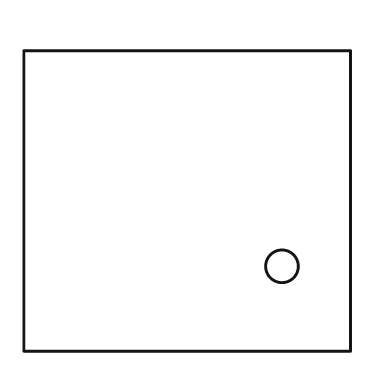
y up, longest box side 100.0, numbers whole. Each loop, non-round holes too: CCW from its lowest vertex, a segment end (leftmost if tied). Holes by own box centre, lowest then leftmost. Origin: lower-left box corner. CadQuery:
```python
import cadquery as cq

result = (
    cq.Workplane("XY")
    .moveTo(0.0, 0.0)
    .lineTo(100.0, 0.0)
    .lineTo(100.0, 92.0)
    .lineTo(0.0, 92.0)
    .close()
    .moveTo(79.0, 26.0)
    .circle(5.0)
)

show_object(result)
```